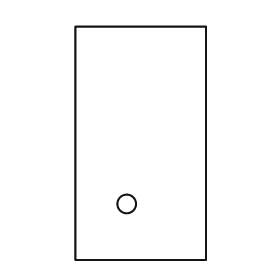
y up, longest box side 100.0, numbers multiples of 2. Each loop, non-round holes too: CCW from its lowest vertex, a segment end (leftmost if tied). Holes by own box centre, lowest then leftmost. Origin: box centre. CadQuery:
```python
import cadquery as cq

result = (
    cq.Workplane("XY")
    .moveTo(-28.0, -50.0)
    .lineTo(28.0, -50.0)
    .lineTo(28.0, 50.0)
    .lineTo(-28.0, 50.0)
    .close()
    .moveTo(-6.0, -26.0)
    .circle(4.0)
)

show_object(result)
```